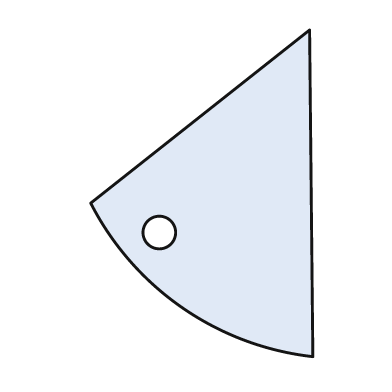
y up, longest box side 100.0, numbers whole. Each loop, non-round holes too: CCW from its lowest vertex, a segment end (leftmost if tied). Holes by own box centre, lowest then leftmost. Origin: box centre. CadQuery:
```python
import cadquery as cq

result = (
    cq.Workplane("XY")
    .moveTo(34.0, -50.0)
    .lineTo(33.0, 50.0)
    .lineTo(-34.0, -3.0)
    .threePointArc((-6.0, -35.0), (34.0, -50.0))
    .close()
    .moveTo(-13.0, -12.0)
    .circle(5.0)
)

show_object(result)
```